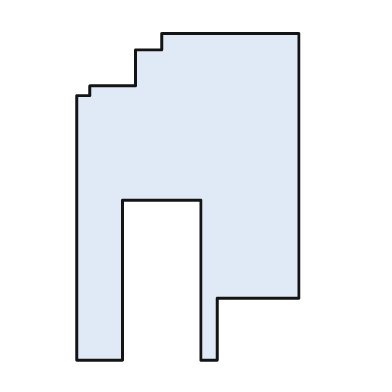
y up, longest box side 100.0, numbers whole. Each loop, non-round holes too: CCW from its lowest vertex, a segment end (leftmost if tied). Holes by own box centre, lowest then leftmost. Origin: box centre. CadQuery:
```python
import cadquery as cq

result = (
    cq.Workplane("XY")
    .moveTo(-34.0, -50.0)
    .lineTo(-20.0, -50.0)
    .lineTo(-20.0, -1.0)
    .lineTo(4.0, -1.0)
    .lineTo(4.0, -50.0)
    .lineTo(9.0, -50.0)
    .lineTo(9.0, -31.0)
    .lineTo(34.0, -31.0)
    .lineTo(34.0, 50.0)
    .lineTo(-8.0, 50.0)
    .lineTo(-8.0, 45.0)
    .lineTo(-16.0, 45.0)
    .lineTo(-16.0, 34.0)
    .lineTo(-30.0, 34.0)
    .lineTo(-30.0, 31.0)
    .lineTo(-34.0, 31.0)
    .close()
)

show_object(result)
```